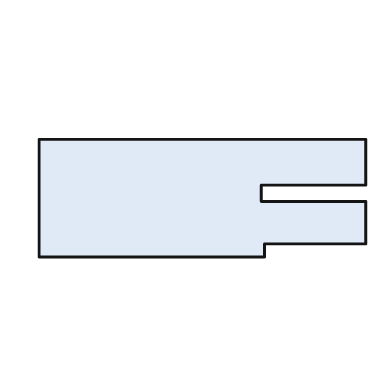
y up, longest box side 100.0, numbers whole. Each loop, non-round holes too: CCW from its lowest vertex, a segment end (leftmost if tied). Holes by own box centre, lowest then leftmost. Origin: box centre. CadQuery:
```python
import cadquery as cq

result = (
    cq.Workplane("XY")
    .moveTo(-50.0, -18.0)
    .lineTo(19.0, -18.0)
    .lineTo(19.0, -14.0)
    .lineTo(50.0, -14.0)
    .lineTo(50.0, -1.0)
    .lineTo(18.0, -1.0)
    .lineTo(18.0, 4.0)
    .lineTo(50.0, 4.0)
    .lineTo(50.0, 18.0)
    .lineTo(-50.0, 18.0)
    .close()
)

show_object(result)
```